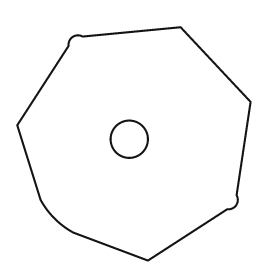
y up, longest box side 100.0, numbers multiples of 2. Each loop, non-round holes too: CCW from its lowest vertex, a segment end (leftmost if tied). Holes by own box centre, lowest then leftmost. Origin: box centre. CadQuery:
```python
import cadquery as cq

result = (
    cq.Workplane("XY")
    .moveTo(6.0, -50.0)
    .lineTo(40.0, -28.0)
    .threePointArc((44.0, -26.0), (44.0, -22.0))
    .lineTo(50.0, 18.0)
    .lineTo(20.0, 50.0)
    .lineTo(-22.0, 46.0)
    .threePointArc((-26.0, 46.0), (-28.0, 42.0))
    .lineTo(-50.0, 8.0)
    .lineTo(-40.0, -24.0)
    .threePointArc((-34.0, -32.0), (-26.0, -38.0))
    .close()
    .moveTo(-2.0, 2.0)
    .circle(8.0)
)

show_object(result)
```